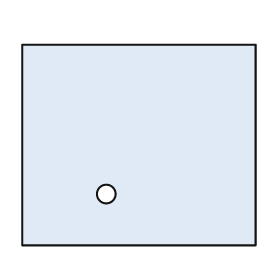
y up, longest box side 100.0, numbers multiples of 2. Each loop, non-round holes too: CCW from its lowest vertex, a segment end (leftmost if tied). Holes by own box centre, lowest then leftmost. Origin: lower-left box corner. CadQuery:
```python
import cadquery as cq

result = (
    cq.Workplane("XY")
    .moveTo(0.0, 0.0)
    .lineTo(100.0, 0.0)
    .lineTo(100.0, 86.0)
    .lineTo(0.0, 86.0)
    .close()
    .moveTo(36.0, 22.0)
    .circle(4.0)
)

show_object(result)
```